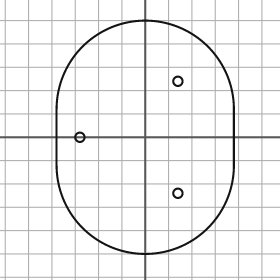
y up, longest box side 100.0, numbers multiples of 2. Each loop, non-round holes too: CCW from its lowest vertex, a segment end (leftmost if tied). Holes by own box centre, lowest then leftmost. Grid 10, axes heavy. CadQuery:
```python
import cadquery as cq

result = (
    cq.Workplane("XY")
    .moveTo(-38.0, -12.0)
    .threePointArc((0.0, -50.0), (38.0, -12.0))
    .lineTo(38.0, 12.0)
    .threePointArc((0.0, 50.0), (-38.0, 12.0))
    .close()
    .moveTo(14.0, -24.0)
    .circle(2.0)
    .moveTo(-28.0, 0.0)
    .circle(2.0)
    .moveTo(14.0, 24.0)
    .circle(2.0)
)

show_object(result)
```